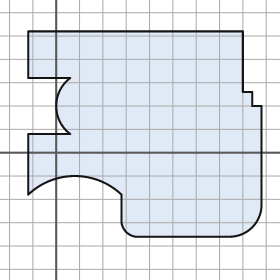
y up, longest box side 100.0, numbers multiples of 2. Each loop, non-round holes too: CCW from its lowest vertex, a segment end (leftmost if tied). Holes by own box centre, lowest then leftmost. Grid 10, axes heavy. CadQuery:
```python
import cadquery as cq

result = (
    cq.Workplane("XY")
    .moveTo(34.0, -36.0)
    .lineTo(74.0, -36.0)
    .threePointArc((84.0, -32.0), (88.0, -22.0))
    .lineTo(88.0, 20.0)
    .lineTo(84.0, 20.0)
    .lineTo(84.0, 26.0)
    .lineTo(80.0, 26.0)
    .lineTo(80.0, 52.0)
    .lineTo(-12.0, 52.0)
    .lineTo(-12.0, 32.0)
    .lineTo(6.0, 32.0)
    .threePointArc((0.0, 20.0), (6.0, 8.0))
    .lineTo(-12.0, 8.0)
    .lineTo(-12.0, -18.0)
    .threePointArc((8.0, -10.0), (28.0, -18.0))
    .lineTo(28.0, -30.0)
    .threePointArc((30.0, -34.0), (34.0, -36.0))
    .close()
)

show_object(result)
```